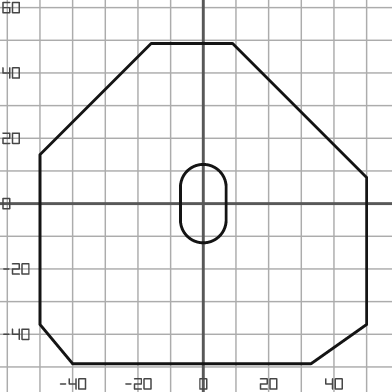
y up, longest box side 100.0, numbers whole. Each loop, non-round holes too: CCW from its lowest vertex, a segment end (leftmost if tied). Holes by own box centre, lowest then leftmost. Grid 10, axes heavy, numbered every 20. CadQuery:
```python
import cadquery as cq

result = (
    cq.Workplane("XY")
    .moveTo(-40.0, -49.0)
    .lineTo(33.0, -49.0)
    .lineTo(50.0, -37.0)
    .lineTo(50.0, 8.0)
    .lineTo(9.0, 49.0)
    .lineTo(-16.0, 49.0)
    .lineTo(-50.0, 15.0)
    .lineTo(-50.0, -37.0)
    .close()
    .moveTo(-7.0, -5.0)
    .threePointArc((0.0, -12.0), (7.0, -5.0))
    .lineTo(7.0, 5.0)
    .threePointArc((0.0, 12.0), (-7.0, 5.0))
    .close()
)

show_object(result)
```